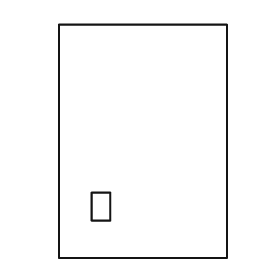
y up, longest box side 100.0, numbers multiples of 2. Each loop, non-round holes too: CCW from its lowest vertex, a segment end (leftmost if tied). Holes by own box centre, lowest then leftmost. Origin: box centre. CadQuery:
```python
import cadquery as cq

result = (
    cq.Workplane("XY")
    .moveTo(-36.0, -50.0)
    .lineTo(36.0, -50.0)
    .lineTo(36.0, 50.0)
    .lineTo(-36.0, 50.0)
    .close()
    .moveTo(-22.0, -34.0)
    .lineTo(-14.0, -34.0)
    .lineTo(-14.0, -22.0)
    .lineTo(-22.0, -22.0)
    .close()
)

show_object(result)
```